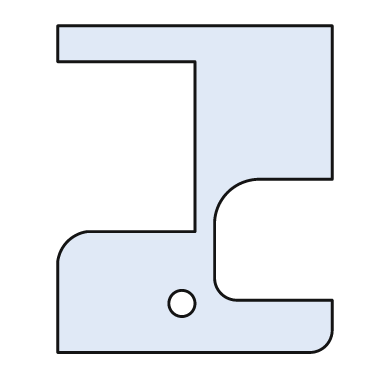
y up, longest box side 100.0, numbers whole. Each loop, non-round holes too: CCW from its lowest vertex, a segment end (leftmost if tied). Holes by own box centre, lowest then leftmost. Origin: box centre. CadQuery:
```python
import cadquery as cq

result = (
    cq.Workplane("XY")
    .moveTo(-42.0, -50.0)
    .lineTo(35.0, -50.0)
    .threePointArc((40.0, -48.0), (42.0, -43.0))
    .lineTo(42.0, -34.0)
    .lineTo(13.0, -34.0)
    .threePointArc((8.0, -32.0), (6.0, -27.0))
    .lineTo(6.0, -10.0)
    .threePointArc((10.0, -1.0), (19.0, 3.0))
    .lineTo(42.0, 3.0)
    .lineTo(42.0, 50.0)
    .lineTo(-42.0, 50.0)
    .lineTo(-42.0, 39.0)
    .lineTo(0.0, 39.0)
    .lineTo(0.0, -13.0)
    .lineTo(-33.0, -13.0)
    .threePointArc((-39.0, -16.0), (-42.0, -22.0))
    .close()
    .moveTo(-4.0, -35.0)
    .circle(4.0)
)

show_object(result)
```